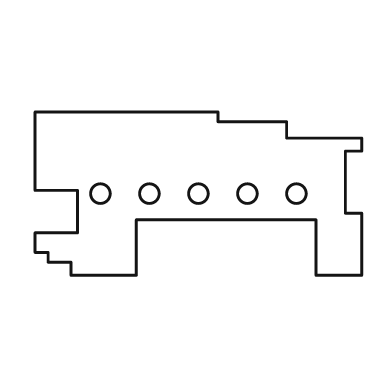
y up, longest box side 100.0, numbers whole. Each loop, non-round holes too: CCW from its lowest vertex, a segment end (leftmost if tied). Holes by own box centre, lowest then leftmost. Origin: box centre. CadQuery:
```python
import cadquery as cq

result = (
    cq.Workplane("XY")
    .moveTo(-39.0, -25.0)
    .lineTo(-19.0, -25.0)
    .lineTo(-19.0, -8.0)
    .lineTo(36.0, -8.0)
    .lineTo(36.0, -25.0)
    .lineTo(50.0, -25.0)
    .lineTo(50.0, -6.0)
    .lineTo(45.0, -6.0)
    .lineTo(45.0, 13.0)
    .lineTo(50.0, 13.0)
    .lineTo(50.0, 17.0)
    .lineTo(27.0, 17.0)
    .lineTo(27.0, 22.0)
    .lineTo(6.0, 22.0)
    .lineTo(6.0, 25.0)
    .lineTo(-50.0, 25.0)
    .lineTo(-50.0, 1.0)
    .lineTo(-37.0, 1.0)
    .lineTo(-37.0, -12.0)
    .lineTo(-50.0, -12.0)
    .lineTo(-50.0, -18.0)
    .lineTo(-46.0, -18.0)
    .lineTo(-46.0, -21.0)
    .lineTo(-39.0, -21.0)
    .close()
    .moveTo(-30.0, 0.0)
    .circle(3.0)
    .moveTo(-15.0, 0.0)
    .circle(3.0)
    .moveTo(0.0, 0.0)
    .circle(3.0)
    .moveTo(15.0, 0.0)
    .circle(3.0)
    .moveTo(30.0, 0.0)
    .circle(3.0)
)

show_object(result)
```